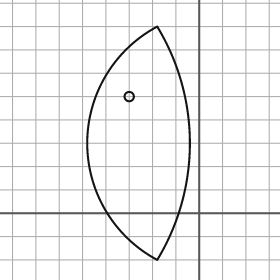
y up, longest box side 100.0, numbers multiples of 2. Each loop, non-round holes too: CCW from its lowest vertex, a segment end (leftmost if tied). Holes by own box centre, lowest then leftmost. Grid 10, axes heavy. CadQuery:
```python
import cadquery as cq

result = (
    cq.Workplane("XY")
    .moveTo(-18.0, -20.0)
    .threePointArc((-4.0, 30.0), (-18.0, 80.0))
    .threePointArc((-48.0, 30.0), (-18.0, -20.0))
    .close()
    .moveTo(-30.0, 50.0)
    .circle(2.0)
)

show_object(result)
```